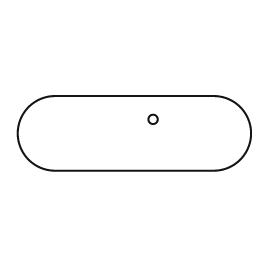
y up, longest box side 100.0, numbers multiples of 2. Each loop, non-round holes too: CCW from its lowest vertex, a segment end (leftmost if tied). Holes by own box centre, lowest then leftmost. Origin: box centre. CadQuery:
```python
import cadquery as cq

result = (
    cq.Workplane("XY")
    .moveTo(-34.0, -16.0)
    .lineTo(34.0, -16.0)
    .threePointArc((50.0, 0.0), (34.0, 16.0))
    .lineTo(-34.0, 16.0)
    .threePointArc((-50.0, 0.0), (-34.0, -16.0))
    .close()
    .moveTo(8.0, 6.0)
    .circle(2.0)
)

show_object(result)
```